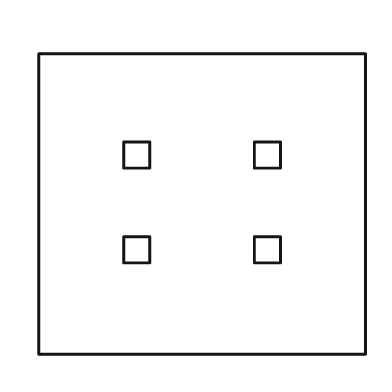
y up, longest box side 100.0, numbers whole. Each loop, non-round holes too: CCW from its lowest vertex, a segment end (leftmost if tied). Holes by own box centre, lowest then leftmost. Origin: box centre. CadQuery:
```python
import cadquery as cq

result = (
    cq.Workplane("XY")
    .moveTo(-50.0, -46.0)
    .lineTo(50.0, -46.0)
    .lineTo(50.0, 46.0)
    .lineTo(-50.0, 46.0)
    .close()
    .moveTo(-24.0, -18.0)
    .lineTo(-16.0, -18.0)
    .lineTo(-16.0, -10.0)
    .lineTo(-24.0, -10.0)
    .close()
    .moveTo(16.0, -18.0)
    .lineTo(24.0, -18.0)
    .lineTo(24.0, -10.0)
    .lineTo(16.0, -10.0)
    .close()
    .moveTo(-24.0, 11.0)
    .lineTo(-16.0, 11.0)
    .lineTo(-16.0, 19.0)
    .lineTo(-24.0, 19.0)
    .close()
    .moveTo(16.0, 11.0)
    .lineTo(24.0, 11.0)
    .lineTo(24.0, 19.0)
    .lineTo(16.0, 19.0)
    .close()
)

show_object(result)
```